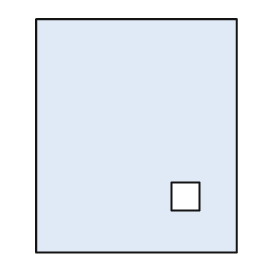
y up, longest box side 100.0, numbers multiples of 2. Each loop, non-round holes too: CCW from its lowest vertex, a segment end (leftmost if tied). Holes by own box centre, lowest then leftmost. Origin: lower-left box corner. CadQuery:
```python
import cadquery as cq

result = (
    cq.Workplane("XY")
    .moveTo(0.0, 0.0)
    .lineTo(86.0, 0.0)
    .lineTo(86.0, 100.0)
    .lineTo(0.0, 100.0)
    .close()
    .moveTo(58.0, 18.0)
    .lineTo(70.0, 18.0)
    .lineTo(70.0, 30.0)
    .lineTo(58.0, 30.0)
    .close()
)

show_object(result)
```